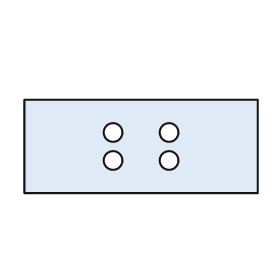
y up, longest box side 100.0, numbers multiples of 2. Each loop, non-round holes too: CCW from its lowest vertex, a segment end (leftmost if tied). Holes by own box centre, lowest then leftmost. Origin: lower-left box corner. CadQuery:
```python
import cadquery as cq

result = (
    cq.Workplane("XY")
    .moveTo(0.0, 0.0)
    .lineTo(100.0, 0.0)
    .lineTo(100.0, 40.0)
    .lineTo(0.0, 40.0)
    .close()
    .moveTo(38.0, 14.0)
    .circle(4.0)
    .moveTo(62.0, 14.0)
    .circle(4.0)
    .moveTo(38.0, 26.0)
    .circle(4.0)
    .moveTo(62.0, 26.0)
    .circle(4.0)
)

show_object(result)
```